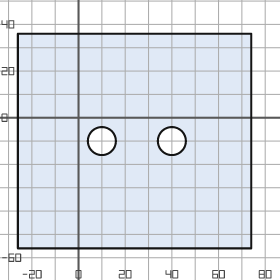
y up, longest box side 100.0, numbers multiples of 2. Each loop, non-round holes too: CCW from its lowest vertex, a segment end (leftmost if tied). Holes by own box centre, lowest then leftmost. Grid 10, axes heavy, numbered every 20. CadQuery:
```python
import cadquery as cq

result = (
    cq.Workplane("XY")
    .moveTo(-26.0, -56.0)
    .lineTo(74.0, -56.0)
    .lineTo(74.0, 36.0)
    .lineTo(-26.0, 36.0)
    .close()
    .moveTo(10.0, -10.0)
    .circle(6.0)
    .moveTo(40.0, -10.0)
    .circle(6.0)
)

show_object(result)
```